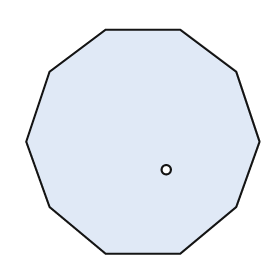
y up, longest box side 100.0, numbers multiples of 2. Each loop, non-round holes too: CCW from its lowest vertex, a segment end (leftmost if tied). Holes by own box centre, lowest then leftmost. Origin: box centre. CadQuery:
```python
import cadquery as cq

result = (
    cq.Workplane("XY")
    .moveTo(-16.0, -48.0)
    .lineTo(16.0, -48.0)
    .lineTo(40.0, -28.0)
    .lineTo(50.0, 0.0)
    .lineTo(40.0, 30.0)
    .lineTo(16.0, 48.0)
    .lineTo(-16.0, 48.0)
    .lineTo(-40.0, 30.0)
    .lineTo(-50.0, 0.0)
    .lineTo(-40.0, -28.0)
    .close()
    .moveTo(10.0, -12.0)
    .circle(2.0)
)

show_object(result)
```